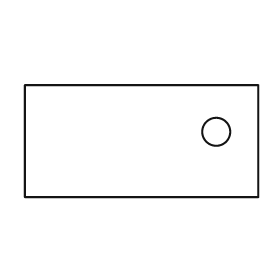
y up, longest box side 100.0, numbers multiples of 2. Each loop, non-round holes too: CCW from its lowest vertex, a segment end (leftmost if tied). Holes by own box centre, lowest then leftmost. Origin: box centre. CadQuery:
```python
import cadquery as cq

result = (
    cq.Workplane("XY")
    .moveTo(-50.0, -24.0)
    .lineTo(50.0, -24.0)
    .lineTo(50.0, 24.0)
    .lineTo(-50.0, 24.0)
    .close()
    .moveTo(32.0, 4.0)
    .circle(6.0)
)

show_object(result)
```